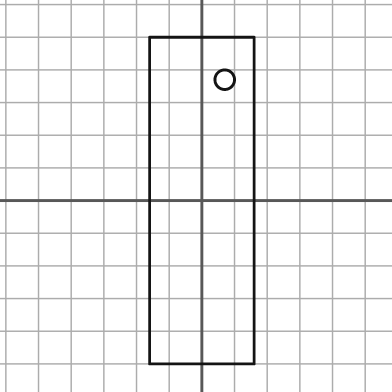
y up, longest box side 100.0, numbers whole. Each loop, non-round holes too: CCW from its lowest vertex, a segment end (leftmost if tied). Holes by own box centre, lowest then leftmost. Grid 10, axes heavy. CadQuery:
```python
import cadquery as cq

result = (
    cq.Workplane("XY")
    .moveTo(-16.0, -50.0)
    .lineTo(16.0, -50.0)
    .lineTo(16.0, 50.0)
    .lineTo(-16.0, 50.0)
    .close()
    .moveTo(7.0, 37.0)
    .circle(3.0)
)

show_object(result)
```